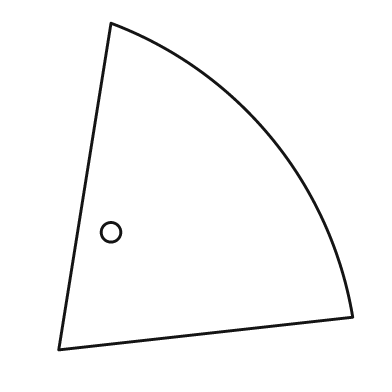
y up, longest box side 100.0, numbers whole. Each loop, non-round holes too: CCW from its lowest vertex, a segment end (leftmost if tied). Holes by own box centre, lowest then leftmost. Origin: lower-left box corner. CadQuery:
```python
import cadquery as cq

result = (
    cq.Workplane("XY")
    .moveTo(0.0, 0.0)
    .lineTo(90.0, 10.0)
    .threePointArc((65.0, 65.0), (16.0, 100.0))
    .close()
    .moveTo(16.0, 36.0)
    .circle(3.0)
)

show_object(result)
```